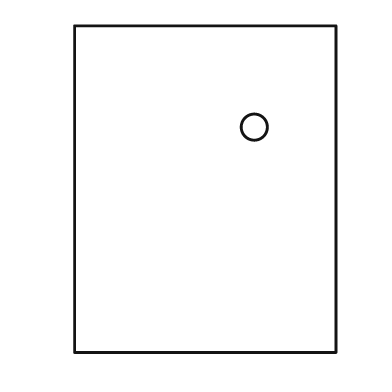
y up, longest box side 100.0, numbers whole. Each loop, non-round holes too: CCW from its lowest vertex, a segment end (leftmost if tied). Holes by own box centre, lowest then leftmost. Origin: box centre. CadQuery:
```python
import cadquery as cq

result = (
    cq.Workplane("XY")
    .moveTo(-40.0, -50.0)
    .lineTo(40.0, -50.0)
    .lineTo(40.0, 50.0)
    .lineTo(-40.0, 50.0)
    .close()
    .moveTo(15.0, 19.0)
    .circle(4.0)
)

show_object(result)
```